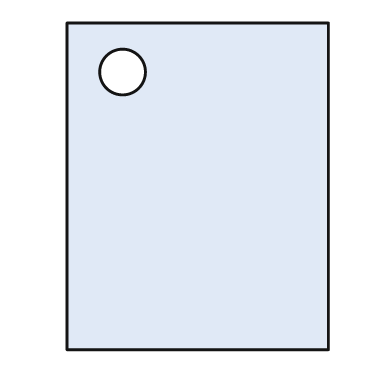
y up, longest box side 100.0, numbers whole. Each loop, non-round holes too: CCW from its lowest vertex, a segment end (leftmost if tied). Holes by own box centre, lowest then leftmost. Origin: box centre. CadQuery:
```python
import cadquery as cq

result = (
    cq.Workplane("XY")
    .moveTo(-40.0, -50.0)
    .lineTo(40.0, -50.0)
    .lineTo(40.0, 50.0)
    .lineTo(-40.0, 50.0)
    .close()
    .moveTo(-23.0, 35.0)
    .circle(7.0)
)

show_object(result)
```